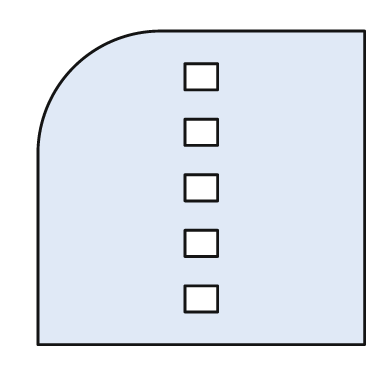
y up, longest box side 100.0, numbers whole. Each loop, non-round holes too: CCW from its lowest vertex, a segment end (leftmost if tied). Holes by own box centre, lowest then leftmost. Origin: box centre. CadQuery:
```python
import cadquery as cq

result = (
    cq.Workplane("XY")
    .moveTo(-50.0, -48.0)
    .lineTo(50.0, -48.0)
    .lineTo(50.0, 48.0)
    .lineTo(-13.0, 48.0)
    .threePointArc((-39.0, 37.0), (-50.0, 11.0))
    .close()
    .moveTo(-5.0, -38.0)
    .lineTo(5.0, -38.0)
    .lineTo(5.0, -30.0)
    .lineTo(-5.0, -30.0)
    .close()
    .moveTo(-5.0, -21.0)
    .lineTo(5.0, -21.0)
    .lineTo(5.0, -13.0)
    .lineTo(-5.0, -13.0)
    .close()
    .moveTo(-5.0, -4.0)
    .lineTo(5.0, -4.0)
    .lineTo(5.0, 4.0)
    .lineTo(-5.0, 4.0)
    .close()
    .moveTo(-5.0, 13.0)
    .lineTo(5.0, 13.0)
    .lineTo(5.0, 21.0)
    .lineTo(-5.0, 21.0)
    .close()
    .moveTo(-5.0, 30.0)
    .lineTo(5.0, 30.0)
    .lineTo(5.0, 38.0)
    .lineTo(-5.0, 38.0)
    .close()
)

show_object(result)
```